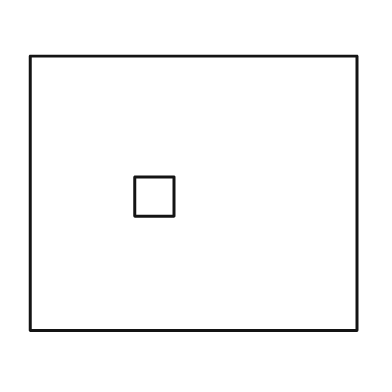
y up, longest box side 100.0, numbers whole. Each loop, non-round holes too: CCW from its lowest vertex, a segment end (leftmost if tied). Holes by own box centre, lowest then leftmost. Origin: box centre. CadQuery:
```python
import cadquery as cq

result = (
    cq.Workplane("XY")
    .moveTo(-50.0, -42.0)
    .lineTo(50.0, -42.0)
    .lineTo(50.0, 42.0)
    .lineTo(-50.0, 42.0)
    .close()
    .moveTo(-18.0, -7.0)
    .lineTo(-6.0, -7.0)
    .lineTo(-6.0, 5.0)
    .lineTo(-18.0, 5.0)
    .close()
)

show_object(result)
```